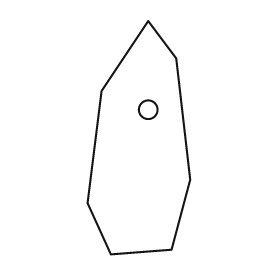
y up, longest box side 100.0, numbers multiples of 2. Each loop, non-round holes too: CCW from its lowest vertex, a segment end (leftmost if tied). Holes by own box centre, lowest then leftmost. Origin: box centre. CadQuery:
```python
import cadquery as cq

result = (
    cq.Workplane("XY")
    .moveTo(-12.0, -50.0)
    .lineTo(14.0, -48.0)
    .lineTo(22.0, -18.0)
    .lineTo(16.0, 34.0)
    .lineTo(4.0, 50.0)
    .lineTo(-16.0, 20.0)
    .lineTo(-22.0, -28.0)
    .close()
    .moveTo(4.0, 12.0)
    .circle(4.0)
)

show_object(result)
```